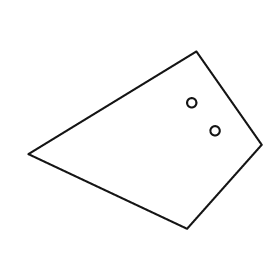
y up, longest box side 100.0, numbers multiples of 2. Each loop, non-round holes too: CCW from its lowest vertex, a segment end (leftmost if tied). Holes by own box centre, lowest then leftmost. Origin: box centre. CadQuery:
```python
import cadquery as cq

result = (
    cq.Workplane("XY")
    .moveTo(18.0, -38.0)
    .lineTo(50.0, -2.0)
    .lineTo(22.0, 38.0)
    .lineTo(-50.0, -6.0)
    .close()
    .moveTo(30.0, 4.0)
    .circle(2.0)
    .moveTo(20.0, 16.0)
    .circle(2.0)
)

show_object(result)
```